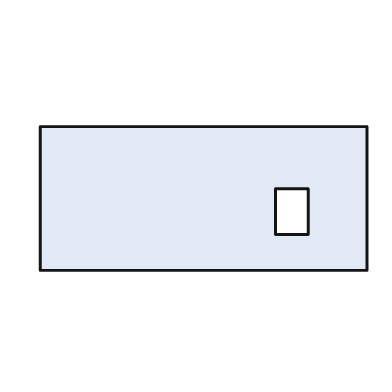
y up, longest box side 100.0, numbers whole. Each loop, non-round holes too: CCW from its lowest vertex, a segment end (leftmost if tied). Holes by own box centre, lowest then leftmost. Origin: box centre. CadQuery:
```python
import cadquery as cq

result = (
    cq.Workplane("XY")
    .moveTo(-50.0, -22.0)
    .lineTo(50.0, -22.0)
    .lineTo(50.0, 22.0)
    .lineTo(-50.0, 22.0)
    .close()
    .moveTo(22.0, -11.0)
    .lineTo(32.0, -11.0)
    .lineTo(32.0, 3.0)
    .lineTo(22.0, 3.0)
    .close()
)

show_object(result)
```